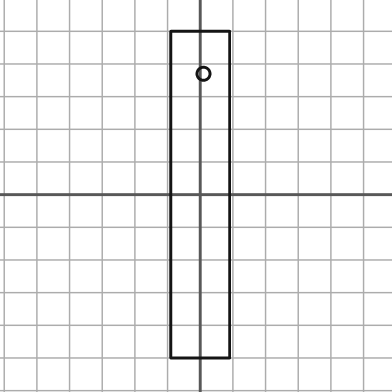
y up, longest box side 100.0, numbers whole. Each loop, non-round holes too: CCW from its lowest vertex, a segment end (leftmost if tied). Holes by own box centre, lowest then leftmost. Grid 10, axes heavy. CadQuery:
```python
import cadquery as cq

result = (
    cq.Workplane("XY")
    .moveTo(-9.0, -50.0)
    .lineTo(9.0, -50.0)
    .lineTo(9.0, 50.0)
    .lineTo(-9.0, 50.0)
    .close()
    .moveTo(1.0, 37.0)
    .circle(2.0)
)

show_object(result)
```